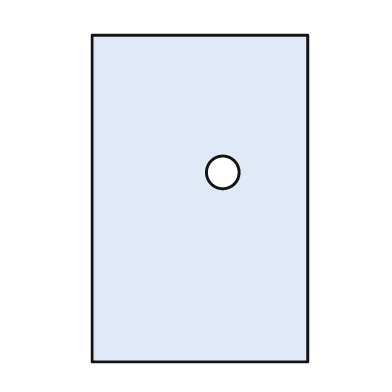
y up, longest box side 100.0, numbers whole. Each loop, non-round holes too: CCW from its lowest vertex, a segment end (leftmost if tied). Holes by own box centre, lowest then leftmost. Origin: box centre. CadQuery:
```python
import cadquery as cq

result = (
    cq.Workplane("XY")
    .moveTo(-33.0, -50.0)
    .lineTo(33.0, -50.0)
    .lineTo(33.0, 50.0)
    .lineTo(-33.0, 50.0)
    .close()
    .moveTo(7.0, 8.0)
    .circle(5.0)
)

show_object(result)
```